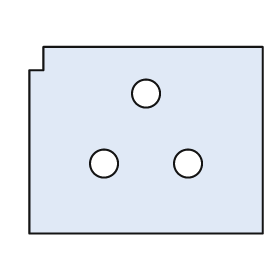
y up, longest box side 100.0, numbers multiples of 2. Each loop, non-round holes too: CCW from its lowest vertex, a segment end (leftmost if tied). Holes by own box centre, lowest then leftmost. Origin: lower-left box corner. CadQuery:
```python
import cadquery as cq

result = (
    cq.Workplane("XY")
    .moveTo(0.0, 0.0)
    .lineTo(100.0, 0.0)
    .lineTo(100.0, 80.0)
    .lineTo(6.0, 80.0)
    .lineTo(6.0, 70.0)
    .lineTo(0.0, 70.0)
    .close()
    .moveTo(32.0, 30.0)
    .circle(6.0)
    .moveTo(68.0, 30.0)
    .circle(6.0)
    .moveTo(50.0, 60.0)
    .circle(6.0)
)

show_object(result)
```